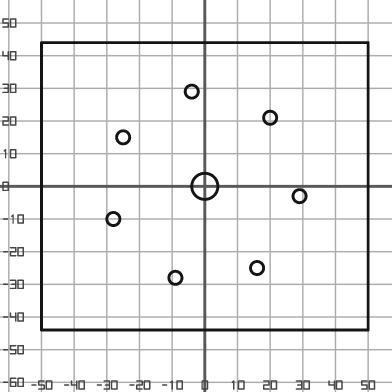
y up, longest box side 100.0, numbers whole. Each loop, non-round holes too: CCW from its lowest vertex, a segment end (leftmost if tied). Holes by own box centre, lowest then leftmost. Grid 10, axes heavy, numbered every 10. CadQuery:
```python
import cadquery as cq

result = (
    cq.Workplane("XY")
    .moveTo(-50.0, -44.0)
    .lineTo(50.0, -44.0)
    .lineTo(50.0, 44.0)
    .lineTo(-50.0, 44.0)
    .close()
    .moveTo(-9.0, -28.0)
    .circle(2.0)
    .moveTo(16.0, -25.0)
    .circle(2.0)
    .moveTo(-28.0, -10.0)
    .circle(2.0)
    .moveTo(29.0, -3.0)
    .circle(2.0)
    .moveTo(0.0, 0.0)
    .circle(4.0)
    .moveTo(-25.0, 15.0)
    .circle(2.0)
    .moveTo(20.0, 21.0)
    .circle(2.0)
    .moveTo(-4.0, 29.0)
    .circle(2.0)
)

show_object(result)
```